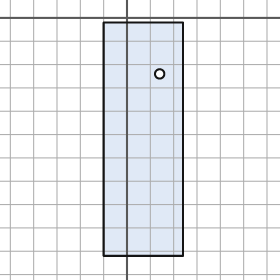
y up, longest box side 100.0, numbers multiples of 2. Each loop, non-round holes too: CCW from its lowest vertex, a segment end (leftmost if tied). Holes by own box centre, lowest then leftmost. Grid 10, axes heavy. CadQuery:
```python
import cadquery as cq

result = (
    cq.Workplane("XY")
    .moveTo(-10.0, -102.0)
    .lineTo(24.0, -102.0)
    .lineTo(24.0, -2.0)
    .lineTo(-10.0, -2.0)
    .close()
    .moveTo(14.0, -24.0)
    .circle(2.0)
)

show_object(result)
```